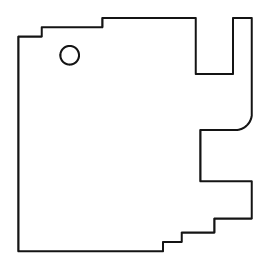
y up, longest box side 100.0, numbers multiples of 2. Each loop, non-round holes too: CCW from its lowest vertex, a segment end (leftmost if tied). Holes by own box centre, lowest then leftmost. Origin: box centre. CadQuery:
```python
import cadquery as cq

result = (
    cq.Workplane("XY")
    .moveTo(-50.0, -50.0)
    .lineTo(12.0, -50.0)
    .lineTo(12.0, -46.0)
    .lineTo(20.0, -46.0)
    .lineTo(20.0, -42.0)
    .lineTo(34.0, -42.0)
    .lineTo(34.0, -36.0)
    .lineTo(50.0, -36.0)
    .lineTo(50.0, -20.0)
    .lineTo(28.0, -20.0)
    .lineTo(28.0, 2.0)
    .lineTo(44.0, 2.0)
    .threePointArc((48.0, 4.0), (50.0, 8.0))
    .lineTo(50.0, 50.0)
    .lineTo(42.0, 50.0)
    .lineTo(42.0, 26.0)
    .lineTo(26.0, 26.0)
    .lineTo(26.0, 50.0)
    .lineTo(-14.0, 50.0)
    .lineTo(-14.0, 46.0)
    .lineTo(-40.0, 46.0)
    .lineTo(-40.0, 42.0)
    .lineTo(-50.0, 42.0)
    .close()
    .moveTo(-28.0, 34.0)
    .circle(4.0)
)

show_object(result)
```